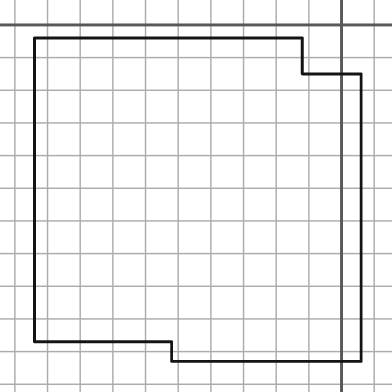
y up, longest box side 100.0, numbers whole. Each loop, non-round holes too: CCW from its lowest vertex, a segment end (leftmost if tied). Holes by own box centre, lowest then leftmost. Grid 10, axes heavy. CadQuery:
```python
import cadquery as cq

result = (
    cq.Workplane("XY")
    .moveTo(-52.0, -103.0)
    .lineTo(6.0, -103.0)
    .lineTo(6.0, -15.0)
    .lineTo(-12.0, -15.0)
    .lineTo(-12.0, -4.0)
    .lineTo(-94.0, -4.0)
    .lineTo(-94.0, -97.0)
    .lineTo(-52.0, -97.0)
    .close()
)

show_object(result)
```